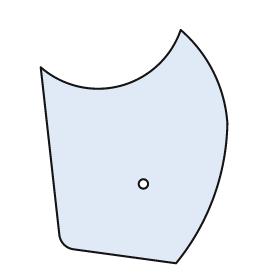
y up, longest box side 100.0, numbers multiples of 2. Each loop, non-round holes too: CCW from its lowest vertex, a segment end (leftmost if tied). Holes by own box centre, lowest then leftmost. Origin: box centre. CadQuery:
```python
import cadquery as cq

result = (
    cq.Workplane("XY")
    .moveTo(18.0, -50.0)
    .threePointArc((34.0, -22.0), (40.0, 10.0))
    .threePointArc((34.0, 32.0), (20.0, 50.0))
    .threePointArc((-6.0, 26.0), (-40.0, 34.0))
    .lineTo(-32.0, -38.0)
    .threePointArc((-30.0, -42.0), (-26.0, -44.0))
    .close()
    .moveTo(4.0, -16.0)
    .circle(2.0)
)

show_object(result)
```